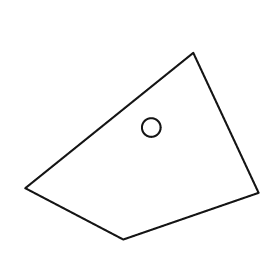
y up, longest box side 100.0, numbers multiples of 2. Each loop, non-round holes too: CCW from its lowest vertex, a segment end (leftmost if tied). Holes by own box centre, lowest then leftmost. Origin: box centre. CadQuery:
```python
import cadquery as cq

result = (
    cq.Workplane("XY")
    .moveTo(-8.0, -40.0)
    .lineTo(50.0, -20.0)
    .lineTo(22.0, 40.0)
    .lineTo(-50.0, -18.0)
    .close()
    .moveTo(4.0, 8.0)
    .circle(4.0)
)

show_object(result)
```